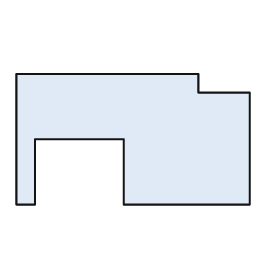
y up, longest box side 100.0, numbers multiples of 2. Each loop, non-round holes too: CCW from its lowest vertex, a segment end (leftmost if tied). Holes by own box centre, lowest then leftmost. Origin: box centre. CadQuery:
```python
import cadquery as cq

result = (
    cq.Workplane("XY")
    .moveTo(-50.0, -28.0)
    .lineTo(-42.0, -28.0)
    .lineTo(-42.0, 0.0)
    .lineTo(-4.0, 0.0)
    .lineTo(-4.0, -28.0)
    .lineTo(50.0, -28.0)
    .lineTo(50.0, 20.0)
    .lineTo(28.0, 20.0)
    .lineTo(28.0, 28.0)
    .lineTo(-50.0, 28.0)
    .close()
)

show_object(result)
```